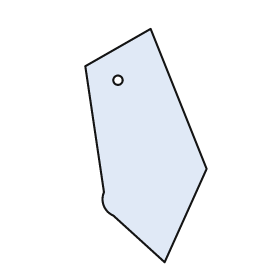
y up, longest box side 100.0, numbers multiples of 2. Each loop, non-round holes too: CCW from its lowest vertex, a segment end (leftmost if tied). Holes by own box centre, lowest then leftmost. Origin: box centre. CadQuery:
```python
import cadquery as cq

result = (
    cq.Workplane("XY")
    .moveTo(8.0, -50.0)
    .lineTo(26.0, -10.0)
    .lineTo(2.0, 50.0)
    .lineTo(-26.0, 34.0)
    .lineTo(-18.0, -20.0)
    .threePointArc((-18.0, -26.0), (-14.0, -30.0))
    .close()
    .moveTo(-12.0, 28.0)
    .circle(2.0)
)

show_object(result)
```